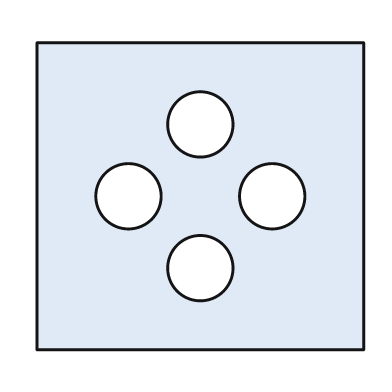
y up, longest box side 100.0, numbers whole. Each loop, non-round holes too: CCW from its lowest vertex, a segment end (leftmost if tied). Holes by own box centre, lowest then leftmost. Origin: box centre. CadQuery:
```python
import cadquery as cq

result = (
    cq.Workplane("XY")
    .moveTo(-50.0, -47.0)
    .lineTo(50.0, -47.0)
    .lineTo(50.0, 47.0)
    .lineTo(-50.0, 47.0)
    .close()
    .moveTo(0.0, -22.0)
    .circle(10.0)
    .moveTo(-22.0, 0.0)
    .circle(10.0)
    .moveTo(22.0, 0.0)
    .circle(10.0)
    .moveTo(0.0, 22.0)
    .circle(10.0)
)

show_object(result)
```